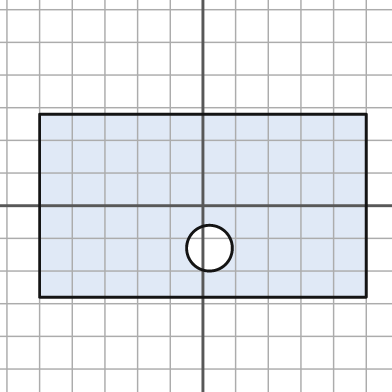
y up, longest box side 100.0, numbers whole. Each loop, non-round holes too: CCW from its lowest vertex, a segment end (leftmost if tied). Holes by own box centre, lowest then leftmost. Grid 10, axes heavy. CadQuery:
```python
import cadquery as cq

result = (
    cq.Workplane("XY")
    .moveTo(-50.0, -28.0)
    .lineTo(50.0, -28.0)
    .lineTo(50.0, 28.0)
    .lineTo(-50.0, 28.0)
    .close()
    .moveTo(2.0, -13.0)
    .circle(7.0)
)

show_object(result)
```